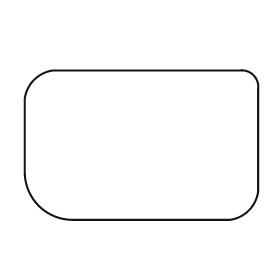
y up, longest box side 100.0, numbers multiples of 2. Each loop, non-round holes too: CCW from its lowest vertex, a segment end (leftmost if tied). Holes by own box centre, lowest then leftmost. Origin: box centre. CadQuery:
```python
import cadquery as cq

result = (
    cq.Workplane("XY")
    .moveTo(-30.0, -32.0)
    .lineTo(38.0, -32.0)
    .threePointArc((46.0, -28.0), (50.0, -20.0))
    .lineTo(50.0, 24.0)
    .threePointArc((48.0, 30.0), (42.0, 32.0))
    .lineTo(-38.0, 32.0)
    .threePointArc((-46.0, 28.0), (-50.0, 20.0))
    .lineTo(-50.0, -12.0)
    .threePointArc((-44.0, -26.0), (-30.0, -32.0))
    .close()
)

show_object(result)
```